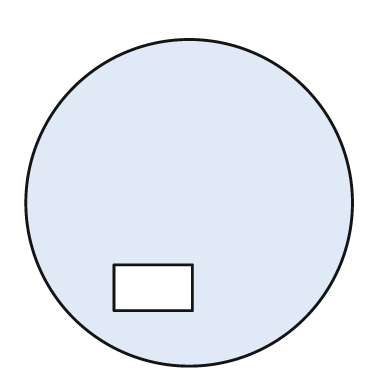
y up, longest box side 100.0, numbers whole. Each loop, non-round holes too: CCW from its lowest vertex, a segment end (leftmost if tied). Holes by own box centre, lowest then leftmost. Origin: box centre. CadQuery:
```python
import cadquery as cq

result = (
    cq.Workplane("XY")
    .moveTo(0.0, 0.0)
    .circle(50.0)
    .moveTo(-23.0, -33.0)
    .lineTo(1.0, -33.0)
    .lineTo(1.0, -19.0)
    .lineTo(-23.0, -19.0)
    .close()
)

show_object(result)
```